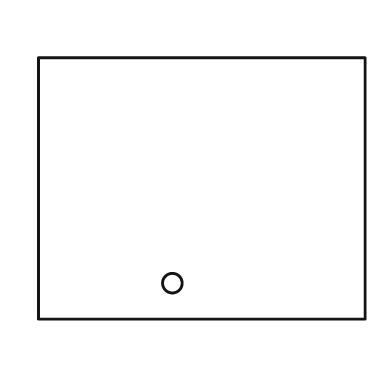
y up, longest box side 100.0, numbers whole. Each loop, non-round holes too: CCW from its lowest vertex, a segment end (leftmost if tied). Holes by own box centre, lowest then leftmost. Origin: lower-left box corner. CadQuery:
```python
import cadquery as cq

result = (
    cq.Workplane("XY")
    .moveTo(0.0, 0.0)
    .lineTo(100.0, 0.0)
    .lineTo(100.0, 80.0)
    .lineTo(0.0, 80.0)
    .close()
    .moveTo(41.0, 11.0)
    .circle(3.0)
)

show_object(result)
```